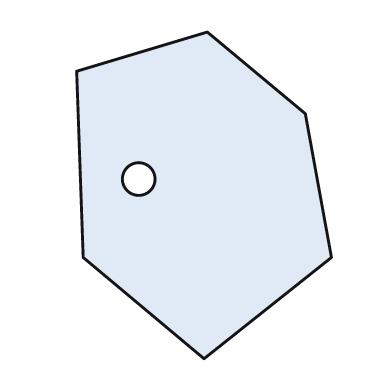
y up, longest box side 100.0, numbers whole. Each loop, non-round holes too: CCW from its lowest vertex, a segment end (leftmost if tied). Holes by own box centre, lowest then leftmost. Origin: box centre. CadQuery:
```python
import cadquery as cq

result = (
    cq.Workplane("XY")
    .moveTo(0.0, -50.0)
    .lineTo(39.0, -19.0)
    .lineTo(31.0, 25.0)
    .lineTo(1.0, 50.0)
    .lineTo(-39.0, 38.0)
    .lineTo(-37.0, -19.0)
    .close()
    .moveTo(-20.0, 5.0)
    .circle(5.0)
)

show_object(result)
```